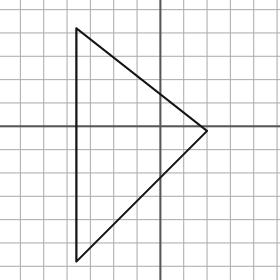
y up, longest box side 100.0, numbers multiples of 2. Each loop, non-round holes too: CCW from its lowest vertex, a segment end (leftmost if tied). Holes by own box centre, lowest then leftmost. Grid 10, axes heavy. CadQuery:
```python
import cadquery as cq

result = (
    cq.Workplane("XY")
    .moveTo(-36.0, -58.0)
    .lineTo(20.0, -2.0)
    .lineTo(-36.0, 42.0)
    .close()
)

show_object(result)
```